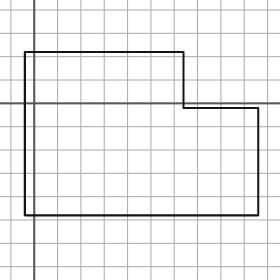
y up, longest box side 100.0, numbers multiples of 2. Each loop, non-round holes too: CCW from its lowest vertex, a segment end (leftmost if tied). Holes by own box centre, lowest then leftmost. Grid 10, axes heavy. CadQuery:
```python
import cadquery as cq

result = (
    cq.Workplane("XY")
    .moveTo(-4.0, -48.0)
    .lineTo(96.0, -48.0)
    .lineTo(96.0, -2.0)
    .lineTo(64.0, -2.0)
    .lineTo(64.0, 22.0)
    .lineTo(-4.0, 22.0)
    .close()
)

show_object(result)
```